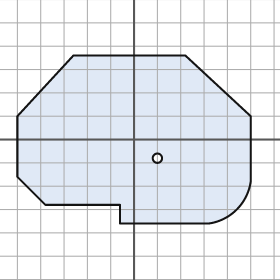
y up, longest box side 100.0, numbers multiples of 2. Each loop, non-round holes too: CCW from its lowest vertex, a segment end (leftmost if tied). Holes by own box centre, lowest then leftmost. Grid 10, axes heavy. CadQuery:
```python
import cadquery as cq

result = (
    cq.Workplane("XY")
    .moveTo(-6.0, -36.0)
    .lineTo(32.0, -36.0)
    .threePointArc((44.0, -30.0), (50.0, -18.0))
    .lineTo(50.0, 10.0)
    .lineTo(22.0, 36.0)
    .lineTo(-26.0, 36.0)
    .lineTo(-50.0, 10.0)
    .lineTo(-50.0, -16.0)
    .lineTo(-38.0, -28.0)
    .lineTo(-6.0, -28.0)
    .close()
    .moveTo(10.0, -8.0)
    .circle(2.0)
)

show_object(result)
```